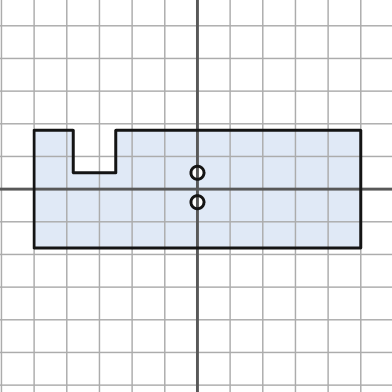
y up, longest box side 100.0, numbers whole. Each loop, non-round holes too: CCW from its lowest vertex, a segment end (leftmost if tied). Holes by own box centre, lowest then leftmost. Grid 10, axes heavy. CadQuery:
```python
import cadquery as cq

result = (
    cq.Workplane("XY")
    .moveTo(-50.0, -18.0)
    .lineTo(50.0, -18.0)
    .lineTo(50.0, 18.0)
    .lineTo(-25.0, 18.0)
    .lineTo(-25.0, 5.0)
    .lineTo(-38.0, 5.0)
    .lineTo(-38.0, 18.0)
    .lineTo(-50.0, 18.0)
    .close()
    .moveTo(0.0, -4.0)
    .circle(2.0)
    .moveTo(0.0, 5.0)
    .circle(2.0)
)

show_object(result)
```